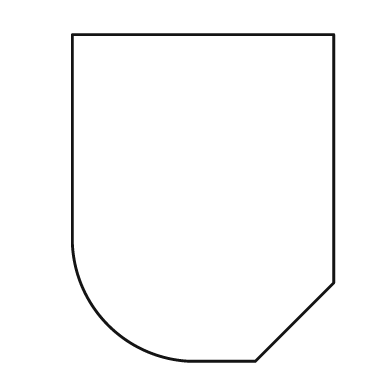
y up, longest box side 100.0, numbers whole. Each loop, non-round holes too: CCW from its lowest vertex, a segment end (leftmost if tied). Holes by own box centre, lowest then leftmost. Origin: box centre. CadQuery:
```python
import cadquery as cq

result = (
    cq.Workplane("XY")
    .moveTo(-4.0, -50.0)
    .lineTo(16.0, -50.0)
    .lineTo(40.0, -26.0)
    .lineTo(40.0, 50.0)
    .lineTo(-40.0, 50.0)
    .lineTo(-40.0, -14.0)
    .threePointArc((-29.0, -39.0), (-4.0, -50.0))
    .close()
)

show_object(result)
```